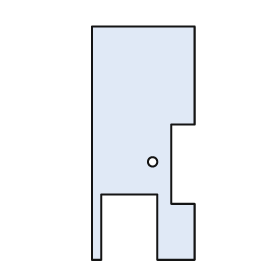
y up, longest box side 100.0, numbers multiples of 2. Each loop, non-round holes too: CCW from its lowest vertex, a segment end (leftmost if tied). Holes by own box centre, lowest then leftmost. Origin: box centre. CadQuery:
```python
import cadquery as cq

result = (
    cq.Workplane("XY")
    .moveTo(-22.0, -50.0)
    .lineTo(-18.0, -50.0)
    .lineTo(-18.0, -22.0)
    .lineTo(6.0, -22.0)
    .lineTo(6.0, -50.0)
    .lineTo(22.0, -50.0)
    .lineTo(22.0, -26.0)
    .lineTo(12.0, -26.0)
    .lineTo(12.0, 8.0)
    .lineTo(22.0, 8.0)
    .lineTo(22.0, 50.0)
    .lineTo(-22.0, 50.0)
    .close()
    .moveTo(4.0, -8.0)
    .circle(2.0)
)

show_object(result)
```